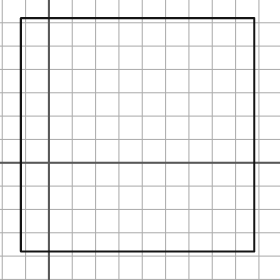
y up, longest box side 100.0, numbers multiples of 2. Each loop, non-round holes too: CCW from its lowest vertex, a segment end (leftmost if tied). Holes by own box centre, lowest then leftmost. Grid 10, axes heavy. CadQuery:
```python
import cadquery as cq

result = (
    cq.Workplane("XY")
    .moveTo(-12.0, -38.0)
    .lineTo(88.0, -38.0)
    .lineTo(88.0, 62.0)
    .lineTo(-12.0, 62.0)
    .close()
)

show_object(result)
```